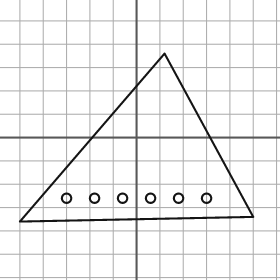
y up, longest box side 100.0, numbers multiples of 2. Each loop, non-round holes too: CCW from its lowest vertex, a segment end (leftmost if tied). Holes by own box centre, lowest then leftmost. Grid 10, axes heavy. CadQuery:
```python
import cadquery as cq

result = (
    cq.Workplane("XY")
    .moveTo(-50.0, -36.0)
    .lineTo(50.0, -34.0)
    .lineTo(12.0, 36.0)
    .close()
    .moveTo(-30.0, -26.0)
    .circle(2.0)
    .moveTo(-18.0, -26.0)
    .circle(2.0)
    .moveTo(-6.0, -26.0)
    .circle(2.0)
    .moveTo(6.0, -26.0)
    .circle(2.0)
    .moveTo(18.0, -26.0)
    .circle(2.0)
    .moveTo(30.0, -26.0)
    .circle(2.0)
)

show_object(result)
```